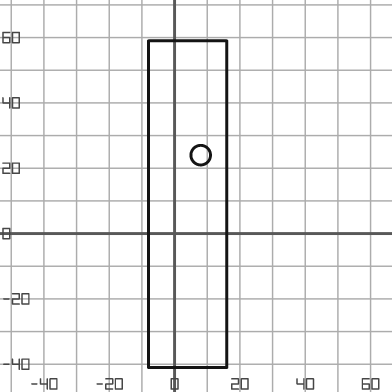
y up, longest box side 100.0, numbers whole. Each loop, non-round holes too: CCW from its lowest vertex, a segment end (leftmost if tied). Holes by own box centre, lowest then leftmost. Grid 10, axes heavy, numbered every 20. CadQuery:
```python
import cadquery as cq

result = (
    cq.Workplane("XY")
    .moveTo(-8.0, -41.0)
    .lineTo(16.0, -41.0)
    .lineTo(16.0, 59.0)
    .lineTo(-8.0, 59.0)
    .close()
    .moveTo(8.0, 24.0)
    .circle(3.0)
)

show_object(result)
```